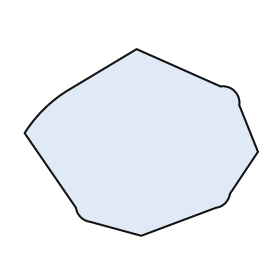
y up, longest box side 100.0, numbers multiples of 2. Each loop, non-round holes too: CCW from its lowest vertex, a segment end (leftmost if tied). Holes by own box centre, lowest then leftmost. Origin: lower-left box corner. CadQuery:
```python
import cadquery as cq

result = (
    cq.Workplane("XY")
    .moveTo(50.0, 0.0)
    .lineTo(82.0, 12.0)
    .threePointArc((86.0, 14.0), (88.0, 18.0))
    .lineTo(100.0, 36.0)
    .lineTo(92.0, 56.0)
    .threePointArc((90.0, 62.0), (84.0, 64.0))
    .lineTo(48.0, 80.0)
    .lineTo(18.0, 62.0)
    .threePointArc((8.0, 54.0), (0.0, 44.0))
    .lineTo(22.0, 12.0)
    .threePointArc((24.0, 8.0), (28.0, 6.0))
    .close()
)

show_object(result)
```